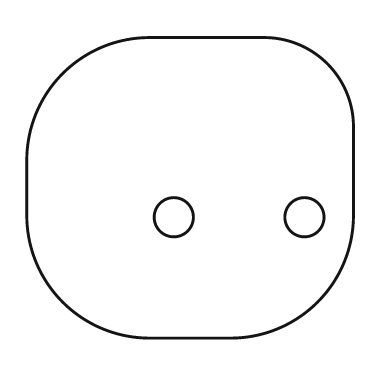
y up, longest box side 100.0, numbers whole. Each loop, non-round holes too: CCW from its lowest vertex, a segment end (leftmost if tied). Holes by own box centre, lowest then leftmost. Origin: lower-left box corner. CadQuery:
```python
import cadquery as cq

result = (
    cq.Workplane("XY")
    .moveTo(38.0, 0.0)
    .lineTo(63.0, 0.0)
    .threePointArc((89.0, 11.0), (100.0, 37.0))
    .lineTo(100.0, 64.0)
    .threePointArc((92.0, 84.0), (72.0, 92.0))
    .lineTo(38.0, 92.0)
    .threePointArc((11.0, 81.0), (0.0, 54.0))
    .lineTo(0.0, 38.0)
    .threePointArc((11.0, 11.0), (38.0, 0.0))
    .close()
    .moveTo(45.0, 37.0)
    .circle(6.0)
    .moveTo(85.0, 37.0)
    .circle(6.0)
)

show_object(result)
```